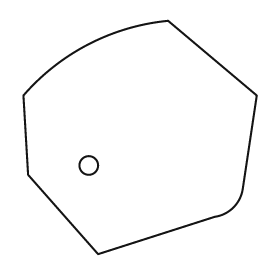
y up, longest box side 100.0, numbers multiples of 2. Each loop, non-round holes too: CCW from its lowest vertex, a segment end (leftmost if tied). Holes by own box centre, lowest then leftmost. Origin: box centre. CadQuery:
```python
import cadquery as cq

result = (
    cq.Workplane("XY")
    .moveTo(-18.0, -50.0)
    .lineTo(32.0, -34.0)
    .threePointArc((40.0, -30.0), (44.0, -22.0))
    .lineTo(50.0, 18.0)
    .lineTo(12.0, 50.0)
    .threePointArc((-22.0, 40.0), (-50.0, 18.0))
    .lineTo(-48.0, -16.0)
    .close()
    .moveTo(-22.0, -12.0)
    .circle(4.0)
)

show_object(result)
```